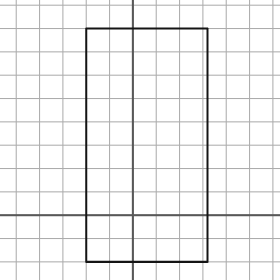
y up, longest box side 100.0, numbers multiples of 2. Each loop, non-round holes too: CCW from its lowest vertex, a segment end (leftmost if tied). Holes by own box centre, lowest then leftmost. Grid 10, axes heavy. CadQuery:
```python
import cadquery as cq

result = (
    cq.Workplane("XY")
    .moveTo(-20.0, -20.0)
    .lineTo(32.0, -20.0)
    .lineTo(32.0, 80.0)
    .lineTo(-20.0, 80.0)
    .close()
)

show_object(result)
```